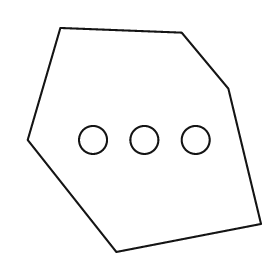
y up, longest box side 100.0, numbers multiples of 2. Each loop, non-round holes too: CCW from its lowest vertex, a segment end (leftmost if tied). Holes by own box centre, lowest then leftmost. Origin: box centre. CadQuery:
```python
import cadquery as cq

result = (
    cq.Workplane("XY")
    .moveTo(-12.0, -48.0)
    .lineTo(50.0, -36.0)
    .lineTo(36.0, 22.0)
    .lineTo(16.0, 46.0)
    .lineTo(-36.0, 48.0)
    .lineTo(-50.0, 0.0)
    .close()
    .moveTo(-22.0, 0.0)
    .circle(6.0)
    .moveTo(0.0, 0.0)
    .circle(6.0)
    .moveTo(22.0, 0.0)
    .circle(6.0)
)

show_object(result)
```